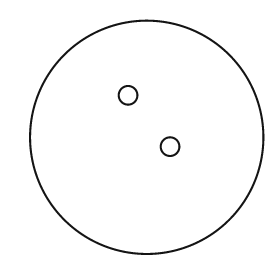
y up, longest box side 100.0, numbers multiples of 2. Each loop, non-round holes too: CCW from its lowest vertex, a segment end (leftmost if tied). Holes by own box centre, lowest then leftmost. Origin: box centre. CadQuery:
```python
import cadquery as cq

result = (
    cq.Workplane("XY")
    .moveTo(0.0, 0.0)
    .circle(50.0)
    .moveTo(10.0, -4.0)
    .circle(4.0)
    .moveTo(-8.0, 18.0)
    .circle(4.0)
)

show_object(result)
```